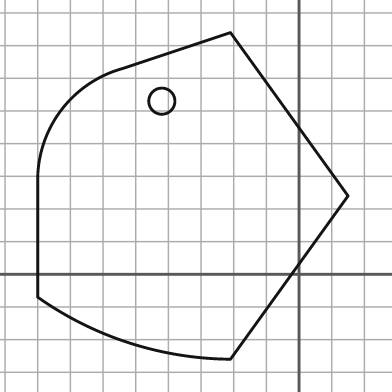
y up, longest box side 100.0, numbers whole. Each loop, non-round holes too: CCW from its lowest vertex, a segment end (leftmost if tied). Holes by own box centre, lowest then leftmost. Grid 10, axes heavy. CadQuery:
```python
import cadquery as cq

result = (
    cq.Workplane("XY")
    .moveTo(-21.0, -26.0)
    .lineTo(15.0, 24.0)
    .lineTo(-21.0, 74.0)
    .lineTo(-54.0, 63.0)
    .threePointArc((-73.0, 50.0), (-80.0, 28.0))
    .lineTo(-80.0, -7.0)
    .threePointArc((-52.0, -21.0), (-21.0, -26.0))
    .close()
    .moveTo(-42.0, 53.0)
    .circle(4.0)
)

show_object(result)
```